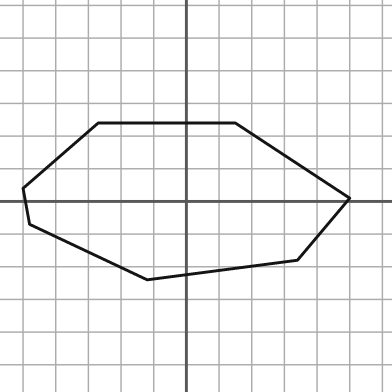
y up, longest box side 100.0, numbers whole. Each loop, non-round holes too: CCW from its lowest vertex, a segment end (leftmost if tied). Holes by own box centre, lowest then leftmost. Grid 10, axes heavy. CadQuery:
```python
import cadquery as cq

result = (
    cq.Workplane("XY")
    .moveTo(-12.0, -24.0)
    .lineTo(34.0, -18.0)
    .lineTo(50.0, 1.0)
    .lineTo(15.0, 24.0)
    .lineTo(-27.0, 24.0)
    .lineTo(-50.0, 4.0)
    .lineTo(-48.0, -7.0)
    .close()
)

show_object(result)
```